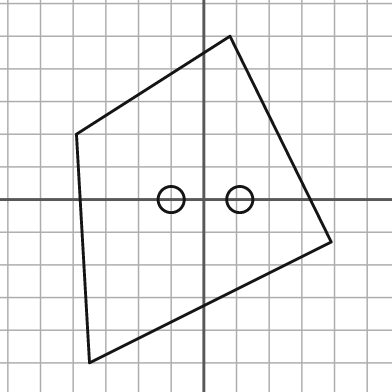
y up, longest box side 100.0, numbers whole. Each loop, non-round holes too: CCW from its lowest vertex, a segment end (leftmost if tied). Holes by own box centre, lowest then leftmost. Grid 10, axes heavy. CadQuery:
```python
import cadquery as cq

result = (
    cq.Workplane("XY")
    .moveTo(-35.0, -50.0)
    .lineTo(39.0, -13.0)
    .lineTo(8.0, 50.0)
    .lineTo(-39.0, 20.0)
    .close()
    .moveTo(-10.0, 0.0)
    .circle(4.0)
    .moveTo(11.0, 0.0)
    .circle(4.0)
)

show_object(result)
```